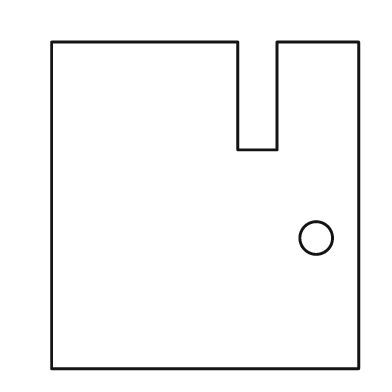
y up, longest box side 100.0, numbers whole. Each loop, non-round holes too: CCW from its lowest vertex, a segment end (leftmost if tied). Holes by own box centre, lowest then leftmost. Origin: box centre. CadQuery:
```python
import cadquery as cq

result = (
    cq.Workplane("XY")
    .moveTo(-47.0, -50.0)
    .lineTo(47.0, -50.0)
    .lineTo(47.0, 50.0)
    .lineTo(22.0, 50.0)
    .lineTo(22.0, 17.0)
    .lineTo(10.0, 17.0)
    .lineTo(10.0, 50.0)
    .lineTo(-47.0, 50.0)
    .close()
    .moveTo(34.0, -10.0)
    .circle(5.0)
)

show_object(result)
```